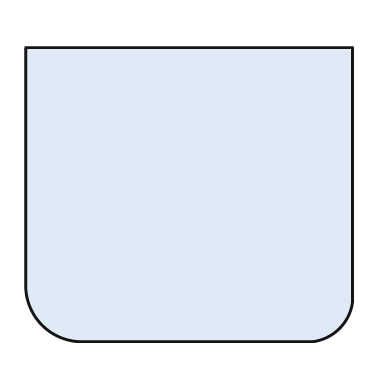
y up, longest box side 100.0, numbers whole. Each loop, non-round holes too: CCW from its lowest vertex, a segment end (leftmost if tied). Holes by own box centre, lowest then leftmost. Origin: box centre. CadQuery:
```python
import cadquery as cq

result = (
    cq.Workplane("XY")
    .moveTo(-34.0, -45.0)
    .lineTo(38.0, -45.0)
    .threePointArc((46.0, -41.0), (50.0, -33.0))
    .lineTo(50.0, 45.0)
    .lineTo(-50.0, 45.0)
    .lineTo(-50.0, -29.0)
    .threePointArc((-45.0, -40.0), (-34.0, -45.0))
    .close()
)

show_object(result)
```